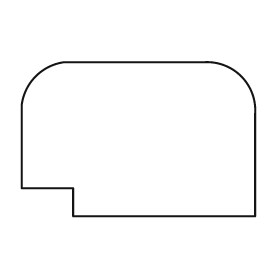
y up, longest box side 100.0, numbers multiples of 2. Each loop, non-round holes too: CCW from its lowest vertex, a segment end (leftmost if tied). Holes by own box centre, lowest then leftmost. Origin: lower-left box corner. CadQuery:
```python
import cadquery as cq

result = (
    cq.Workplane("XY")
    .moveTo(22.0, 0.0)
    .lineTo(100.0, 0.0)
    .lineTo(100.0, 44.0)
    .threePointArc((94.0, 60.0), (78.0, 66.0))
    .lineTo(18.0, 66.0)
    .threePointArc((6.0, 60.0), (0.0, 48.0))
    .lineTo(0.0, 12.0)
    .lineTo(22.0, 12.0)
    .close()
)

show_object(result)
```